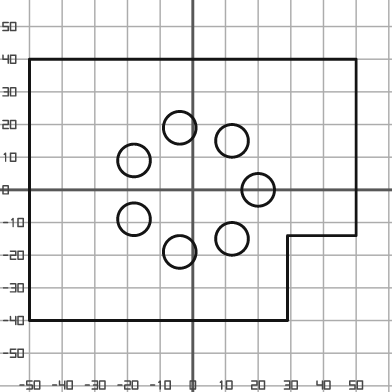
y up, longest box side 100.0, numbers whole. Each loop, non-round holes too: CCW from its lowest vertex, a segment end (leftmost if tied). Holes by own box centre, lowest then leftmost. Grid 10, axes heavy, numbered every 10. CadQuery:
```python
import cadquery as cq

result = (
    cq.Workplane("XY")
    .moveTo(-50.0, -40.0)
    .lineTo(29.0, -40.0)
    .lineTo(29.0, -14.0)
    .lineTo(50.0, -14.0)
    .lineTo(50.0, 40.0)
    .lineTo(-50.0, 40.0)
    .close()
    .moveTo(-4.0, -19.0)
    .circle(5.0)
    .moveTo(12.0, -15.0)
    .circle(5.0)
    .moveTo(-18.0, -9.0)
    .circle(5.0)
    .moveTo(20.0, 0.0)
    .circle(5.0)
    .moveTo(-18.0, 9.0)
    .circle(5.0)
    .moveTo(12.0, 15.0)
    .circle(5.0)
    .moveTo(-4.0, 19.0)
    .circle(5.0)
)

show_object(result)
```